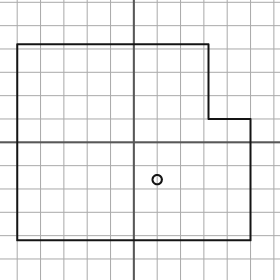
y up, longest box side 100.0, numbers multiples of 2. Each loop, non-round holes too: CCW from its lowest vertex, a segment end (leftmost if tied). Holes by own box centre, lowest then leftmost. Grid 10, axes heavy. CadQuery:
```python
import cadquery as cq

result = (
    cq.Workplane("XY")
    .moveTo(-50.0, -42.0)
    .lineTo(50.0, -42.0)
    .lineTo(50.0, 10.0)
    .lineTo(32.0, 10.0)
    .lineTo(32.0, 42.0)
    .lineTo(-50.0, 42.0)
    .close()
    .moveTo(10.0, -16.0)
    .circle(2.0)
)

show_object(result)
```